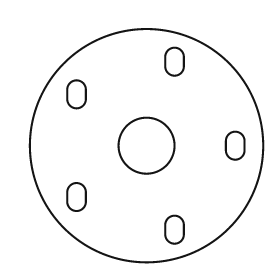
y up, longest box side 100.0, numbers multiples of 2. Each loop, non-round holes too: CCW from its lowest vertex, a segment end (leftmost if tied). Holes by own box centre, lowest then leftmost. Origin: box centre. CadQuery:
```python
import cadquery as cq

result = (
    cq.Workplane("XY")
    .moveTo(0.0, 0.0)
    .circle(50.0)
    .moveTo(8.0, -38.0)
    .threePointArc((12.0, -42.0), (16.0, -38.0))
    .lineTo(16.0, -34.0)
    .threePointArc((12.0, -30.0), (8.0, -34.0))
    .close()
    .moveTo(-34.0, -24.0)
    .threePointArc((-30.0, -28.0), (-26.0, -24.0))
    .lineTo(-26.0, -20.0)
    .threePointArc((-30.0, -16.0), (-34.0, -20.0))
    .close()
    .moveTo(0.0, 0.0)
    .circle(12.0)
    .moveTo(34.0, -2.0)
    .threePointArc((38.0, -6.0), (42.0, -2.0))
    .lineTo(42.0, 2.0)
    .threePointArc((38.0, 6.0), (34.0, 2.0))
    .close()
    .moveTo(-34.0, 20.0)
    .threePointArc((-30.0, 16.0), (-26.0, 20.0))
    .lineTo(-26.0, 24.0)
    .threePointArc((-30.0, 28.0), (-34.0, 24.0))
    .close()
    .moveTo(8.0, 34.0)
    .threePointArc((12.0, 30.0), (16.0, 34.0))
    .lineTo(16.0, 38.0)
    .threePointArc((12.0, 42.0), (8.0, 38.0))
    .close()
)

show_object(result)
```